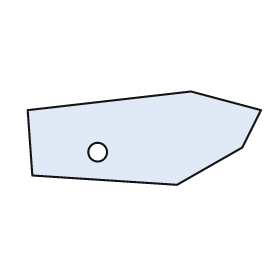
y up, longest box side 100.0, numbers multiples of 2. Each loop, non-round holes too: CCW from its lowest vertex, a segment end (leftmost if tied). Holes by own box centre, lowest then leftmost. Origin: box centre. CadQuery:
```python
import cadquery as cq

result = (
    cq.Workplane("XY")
    .moveTo(14.0, -20.0)
    .lineTo(42.0, -4.0)
    .lineTo(50.0, 12.0)
    .lineTo(20.0, 20.0)
    .lineTo(-50.0, 12.0)
    .lineTo(-48.0, -16.0)
    .close()
    .moveTo(-20.0, -6.0)
    .circle(4.0)
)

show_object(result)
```